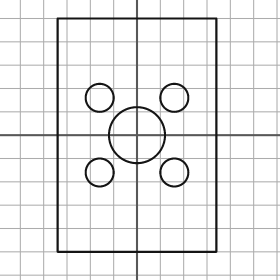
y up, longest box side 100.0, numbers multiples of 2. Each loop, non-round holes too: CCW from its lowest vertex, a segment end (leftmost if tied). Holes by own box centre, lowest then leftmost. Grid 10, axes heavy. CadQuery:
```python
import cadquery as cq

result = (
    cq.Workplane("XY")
    .moveTo(-34.0, -50.0)
    .lineTo(34.0, -50.0)
    .lineTo(34.0, 50.0)
    .lineTo(-34.0, 50.0)
    .close()
    .moveTo(-16.0, -16.0)
    .circle(6.0)
    .moveTo(16.0, -16.0)
    .circle(6.0)
    .moveTo(0.0, 0.0)
    .circle(12.0)
    .moveTo(-16.0, 16.0)
    .circle(6.0)
    .moveTo(16.0, 16.0)
    .circle(6.0)
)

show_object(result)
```